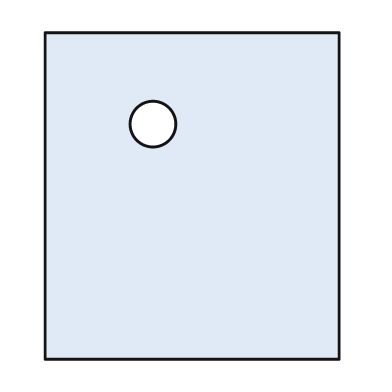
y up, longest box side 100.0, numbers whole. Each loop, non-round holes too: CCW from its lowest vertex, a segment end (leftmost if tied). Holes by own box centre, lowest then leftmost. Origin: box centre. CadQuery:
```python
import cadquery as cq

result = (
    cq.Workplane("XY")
    .moveTo(-45.0, -50.0)
    .lineTo(45.0, -50.0)
    .lineTo(45.0, 50.0)
    .lineTo(-45.0, 50.0)
    .close()
    .moveTo(-12.0, 22.0)
    .circle(7.0)
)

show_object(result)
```